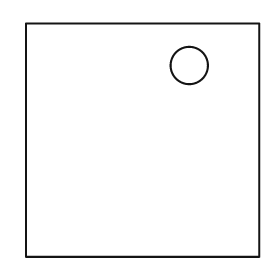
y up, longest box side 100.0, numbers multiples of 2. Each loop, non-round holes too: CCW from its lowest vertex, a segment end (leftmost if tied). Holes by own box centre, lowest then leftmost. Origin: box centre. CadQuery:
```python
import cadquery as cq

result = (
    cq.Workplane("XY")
    .moveTo(-50.0, -50.0)
    .lineTo(50.0, -50.0)
    .lineTo(50.0, 50.0)
    .lineTo(-50.0, 50.0)
    .close()
    .moveTo(20.0, 32.0)
    .circle(8.0)
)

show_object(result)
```